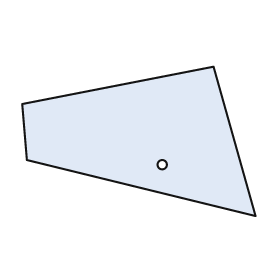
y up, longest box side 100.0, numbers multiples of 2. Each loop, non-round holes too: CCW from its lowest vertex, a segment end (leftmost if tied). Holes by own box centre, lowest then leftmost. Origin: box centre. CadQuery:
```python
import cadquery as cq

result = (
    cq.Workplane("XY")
    .moveTo(50.0, -32.0)
    .lineTo(32.0, 32.0)
    .lineTo(-50.0, 16.0)
    .lineTo(-48.0, -8.0)
    .close()
    .moveTo(10.0, -10.0)
    .circle(2.0)
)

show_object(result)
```